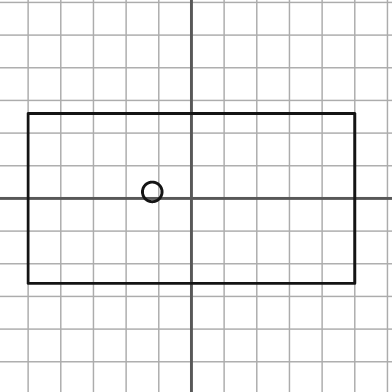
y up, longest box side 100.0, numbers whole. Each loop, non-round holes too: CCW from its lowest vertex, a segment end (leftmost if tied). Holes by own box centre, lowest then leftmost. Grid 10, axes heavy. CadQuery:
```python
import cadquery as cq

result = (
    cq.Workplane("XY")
    .moveTo(-50.0, -26.0)
    .lineTo(50.0, -26.0)
    .lineTo(50.0, 26.0)
    .lineTo(-50.0, 26.0)
    .close()
    .moveTo(-12.0, 2.0)
    .circle(3.0)
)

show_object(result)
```